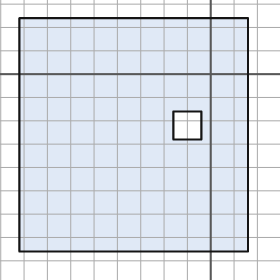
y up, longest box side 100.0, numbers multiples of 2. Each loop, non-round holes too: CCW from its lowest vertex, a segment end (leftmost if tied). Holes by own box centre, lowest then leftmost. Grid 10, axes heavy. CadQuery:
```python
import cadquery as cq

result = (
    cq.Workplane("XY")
    .moveTo(-82.0, -76.0)
    .lineTo(16.0, -76.0)
    .lineTo(16.0, 24.0)
    .lineTo(-82.0, 24.0)
    .close()
    .moveTo(-16.0, -28.0)
    .lineTo(-4.0, -28.0)
    .lineTo(-4.0, -16.0)
    .lineTo(-16.0, -16.0)
    .close()
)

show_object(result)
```